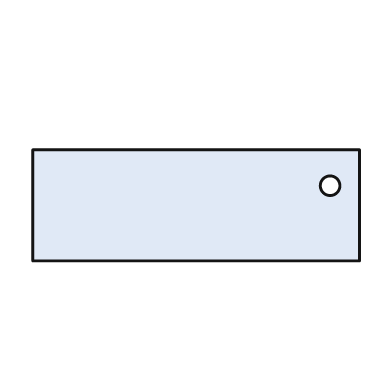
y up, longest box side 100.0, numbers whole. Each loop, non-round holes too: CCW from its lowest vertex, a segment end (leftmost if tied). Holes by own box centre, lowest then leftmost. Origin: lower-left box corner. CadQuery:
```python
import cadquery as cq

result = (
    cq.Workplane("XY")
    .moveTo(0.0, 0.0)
    .lineTo(100.0, 0.0)
    .lineTo(100.0, 34.0)
    .lineTo(0.0, 34.0)
    .close()
    .moveTo(91.0, 23.0)
    .circle(3.0)
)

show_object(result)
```